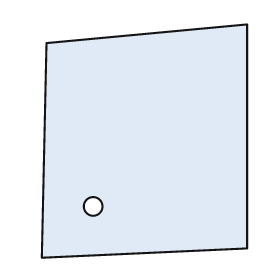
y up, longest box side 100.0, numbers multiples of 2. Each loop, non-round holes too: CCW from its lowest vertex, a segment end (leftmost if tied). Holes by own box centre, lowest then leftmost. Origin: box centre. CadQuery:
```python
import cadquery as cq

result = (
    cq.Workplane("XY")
    .moveTo(-44.0, -50.0)
    .lineTo(44.0, -46.0)
    .lineTo(44.0, 50.0)
    .lineTo(-42.0, 42.0)
    .close()
    .moveTo(-22.0, -28.0)
    .circle(4.0)
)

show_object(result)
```